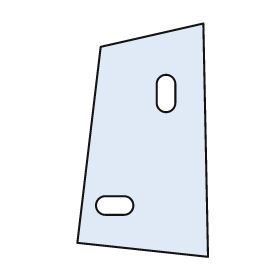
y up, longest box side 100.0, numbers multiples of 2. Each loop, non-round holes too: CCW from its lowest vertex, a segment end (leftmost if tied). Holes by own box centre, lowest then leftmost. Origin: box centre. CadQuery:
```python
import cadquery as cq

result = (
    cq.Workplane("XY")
    .moveTo(28.0, -50.0)
    .lineTo(26.0, 50.0)
    .lineTo(-18.0, 40.0)
    .lineTo(-28.0, -44.0)
    .close()
    .moveTo(-16.0, -32.0)
    .lineTo(-8.0, -32.0)
    .threePointArc((-4.0, -28.0), (-8.0, -24.0))
    .lineTo(-16.0, -24.0)
    .threePointArc((-20.0, -28.0), (-16.0, -32.0))
    .close()
    .moveTo(6.0, 16.0)
    .threePointArc((10.0, 12.0), (14.0, 16.0))
    .lineTo(14.0, 24.0)
    .threePointArc((10.0, 28.0), (6.0, 24.0))
    .close()
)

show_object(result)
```